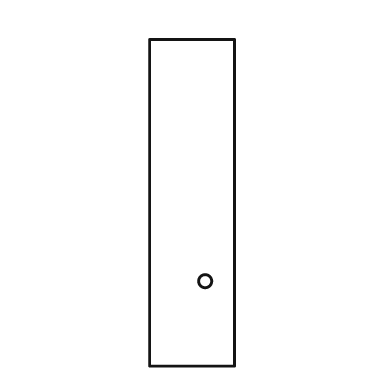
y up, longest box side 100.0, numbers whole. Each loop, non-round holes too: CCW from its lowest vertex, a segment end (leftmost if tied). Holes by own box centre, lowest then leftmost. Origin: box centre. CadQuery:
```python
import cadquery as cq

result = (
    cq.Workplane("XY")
    .moveTo(-13.0, -50.0)
    .lineTo(13.0, -50.0)
    .lineTo(13.0, 50.0)
    .lineTo(-13.0, 50.0)
    .close()
    .moveTo(4.0, -24.0)
    .circle(2.0)
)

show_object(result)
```